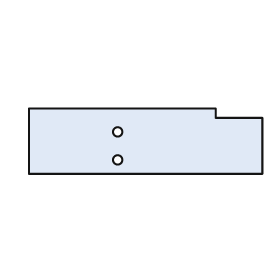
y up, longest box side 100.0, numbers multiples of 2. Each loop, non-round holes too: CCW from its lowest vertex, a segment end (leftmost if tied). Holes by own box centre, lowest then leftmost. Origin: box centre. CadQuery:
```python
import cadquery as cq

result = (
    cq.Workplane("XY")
    .moveTo(-50.0, -14.0)
    .lineTo(50.0, -14.0)
    .lineTo(50.0, 10.0)
    .lineTo(30.0, 10.0)
    .lineTo(30.0, 14.0)
    .lineTo(-50.0, 14.0)
    .close()
    .moveTo(-12.0, -8.0)
    .circle(2.0)
    .moveTo(-12.0, 4.0)
    .circle(2.0)
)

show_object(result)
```